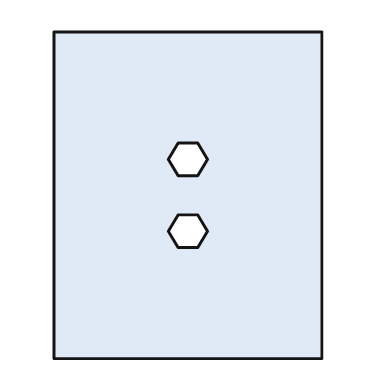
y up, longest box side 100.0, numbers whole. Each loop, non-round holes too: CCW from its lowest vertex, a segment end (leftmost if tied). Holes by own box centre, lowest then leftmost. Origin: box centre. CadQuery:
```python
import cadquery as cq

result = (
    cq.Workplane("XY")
    .moveTo(-41.0, -50.0)
    .lineTo(41.0, -50.0)
    .lineTo(41.0, 50.0)
    .lineTo(-41.0, 50.0)
    .close()
    .moveTo(-3.0, -16.0)
    .lineTo(3.0, -16.0)
    .lineTo(6.0, -11.0)
    .lineTo(3.0, -6.0)
    .lineTo(-3.0, -6.0)
    .lineTo(-6.0, -11.0)
    .close()
    .moveTo(-3.0, 6.0)
    .lineTo(3.0, 6.0)
    .lineTo(6.0, 11.0)
    .lineTo(3.0, 16.0)
    .lineTo(-3.0, 16.0)
    .lineTo(-6.0, 11.0)
    .close()
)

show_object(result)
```